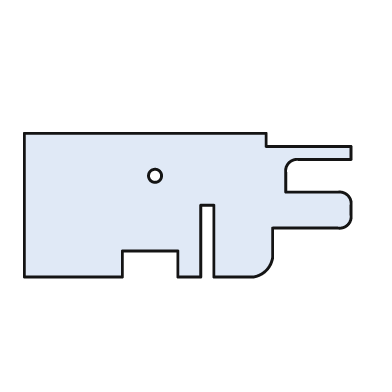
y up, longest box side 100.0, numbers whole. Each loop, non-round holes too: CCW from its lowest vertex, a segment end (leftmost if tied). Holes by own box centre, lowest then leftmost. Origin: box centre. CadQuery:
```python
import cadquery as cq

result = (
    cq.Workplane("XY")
    .moveTo(-50.0, -22.0)
    .lineTo(-20.0, -22.0)
    .lineTo(-20.0, -14.0)
    .lineTo(-3.0, -14.0)
    .lineTo(-3.0, -22.0)
    .lineTo(4.0, -22.0)
    .lineTo(4.0, 0.0)
    .lineTo(8.0, 0.0)
    .lineTo(8.0, -22.0)
    .lineTo(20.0, -22.0)
    .threePointArc((24.0, -20.0), (26.0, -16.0))
    .lineTo(26.0, -7.0)
    .lineTo(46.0, -7.0)
    .threePointArc((49.0, -6.0), (50.0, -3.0))
    .lineTo(50.0, 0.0)
    .threePointArc((49.0, 3.0), (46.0, 4.0))
    .lineTo(30.0, 4.0)
    .lineTo(30.0, 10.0)
    .threePointArc((31.0, 13.0), (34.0, 14.0))
    .lineTo(50.0, 14.0)
    .lineTo(50.0, 18.0)
    .lineTo(24.0, 18.0)
    .lineTo(24.0, 22.0)
    .lineTo(-50.0, 22.0)
    .close()
    .moveTo(-10.0, 9.0)
    .circle(2.0)
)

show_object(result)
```